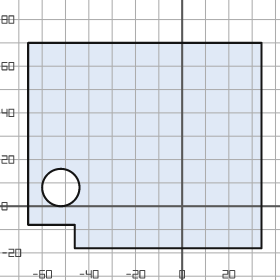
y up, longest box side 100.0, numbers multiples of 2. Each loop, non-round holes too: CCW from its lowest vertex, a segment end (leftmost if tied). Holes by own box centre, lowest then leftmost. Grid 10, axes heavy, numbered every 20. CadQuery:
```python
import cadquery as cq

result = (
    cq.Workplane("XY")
    .moveTo(-46.0, -18.0)
    .lineTo(34.0, -18.0)
    .lineTo(34.0, 70.0)
    .lineTo(-66.0, 70.0)
    .lineTo(-66.0, -8.0)
    .lineTo(-46.0, -8.0)
    .close()
    .moveTo(-52.0, 8.0)
    .circle(8.0)
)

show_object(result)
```